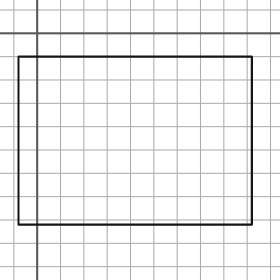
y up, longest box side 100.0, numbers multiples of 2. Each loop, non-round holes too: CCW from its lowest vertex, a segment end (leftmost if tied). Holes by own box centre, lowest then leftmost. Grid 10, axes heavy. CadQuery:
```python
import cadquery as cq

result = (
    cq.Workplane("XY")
    .moveTo(-8.0, -82.0)
    .lineTo(92.0, -82.0)
    .lineTo(92.0, -10.0)
    .lineTo(-8.0, -10.0)
    .close()
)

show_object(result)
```